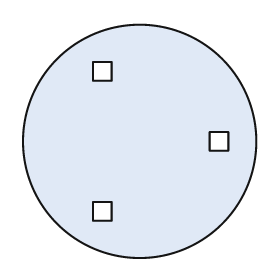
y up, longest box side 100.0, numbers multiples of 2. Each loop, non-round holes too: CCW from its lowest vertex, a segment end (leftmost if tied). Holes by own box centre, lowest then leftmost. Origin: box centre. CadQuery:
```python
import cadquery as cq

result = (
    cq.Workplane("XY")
    .moveTo(0.0, 0.0)
    .circle(50.0)
    .moveTo(-20.0, -34.0)
    .lineTo(-12.0, -34.0)
    .lineTo(-12.0, -26.0)
    .lineTo(-20.0, -26.0)
    .close()
    .moveTo(30.0, -4.0)
    .lineTo(38.0, -4.0)
    .lineTo(38.0, 4.0)
    .lineTo(30.0, 4.0)
    .close()
    .moveTo(-20.0, 26.0)
    .lineTo(-12.0, 26.0)
    .lineTo(-12.0, 34.0)
    .lineTo(-20.0, 34.0)
    .close()
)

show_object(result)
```